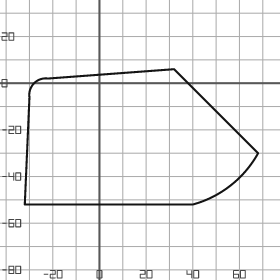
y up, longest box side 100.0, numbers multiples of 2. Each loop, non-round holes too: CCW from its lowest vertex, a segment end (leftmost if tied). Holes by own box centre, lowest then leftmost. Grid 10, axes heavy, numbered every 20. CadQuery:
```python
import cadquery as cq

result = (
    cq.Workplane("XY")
    .moveTo(-32.0, -52.0)
    .lineTo(40.0, -52.0)
    .threePointArc((56.0, -44.0), (68.0, -30.0))
    .lineTo(32.0, 6.0)
    .lineTo(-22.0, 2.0)
    .threePointArc((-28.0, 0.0), (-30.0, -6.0))
    .close()
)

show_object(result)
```